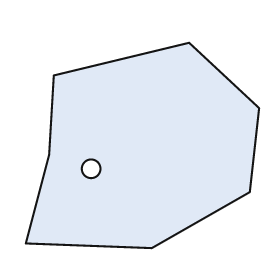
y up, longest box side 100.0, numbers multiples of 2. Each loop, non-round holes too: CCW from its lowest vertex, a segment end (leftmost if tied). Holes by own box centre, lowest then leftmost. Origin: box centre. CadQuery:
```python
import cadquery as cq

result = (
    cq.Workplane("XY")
    .moveTo(4.0, -44.0)
    .lineTo(46.0, -20.0)
    .lineTo(50.0, 16.0)
    .lineTo(20.0, 44.0)
    .lineTo(-38.0, 30.0)
    .lineTo(-40.0, -4.0)
    .lineTo(-50.0, -42.0)
    .close()
    .moveTo(-22.0, -10.0)
    .circle(4.0)
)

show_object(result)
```